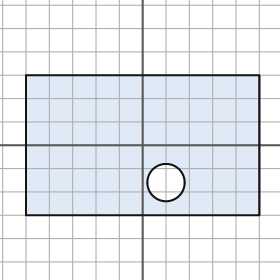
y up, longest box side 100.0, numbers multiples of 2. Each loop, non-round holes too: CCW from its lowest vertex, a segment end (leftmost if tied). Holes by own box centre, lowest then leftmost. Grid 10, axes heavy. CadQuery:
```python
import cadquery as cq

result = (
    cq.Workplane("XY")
    .moveTo(-50.0, -30.0)
    .lineTo(50.0, -30.0)
    .lineTo(50.0, 30.0)
    .lineTo(-50.0, 30.0)
    .close()
    .moveTo(10.0, -16.0)
    .circle(8.0)
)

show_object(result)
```